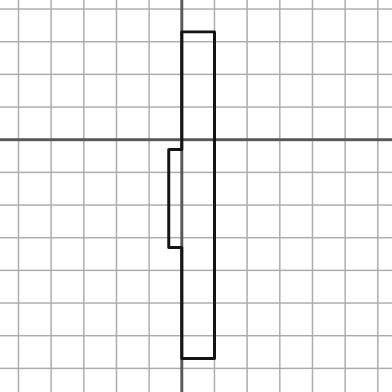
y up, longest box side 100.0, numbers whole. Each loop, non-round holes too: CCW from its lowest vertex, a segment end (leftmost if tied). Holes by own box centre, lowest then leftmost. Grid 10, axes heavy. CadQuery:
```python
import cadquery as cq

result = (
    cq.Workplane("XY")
    .moveTo(0.0, -67.0)
    .lineTo(10.0, -67.0)
    .lineTo(10.0, 33.0)
    .lineTo(0.0, 33.0)
    .lineTo(0.0, -3.0)
    .lineTo(-4.0, -3.0)
    .lineTo(-4.0, -33.0)
    .lineTo(0.0, -33.0)
    .close()
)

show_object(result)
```